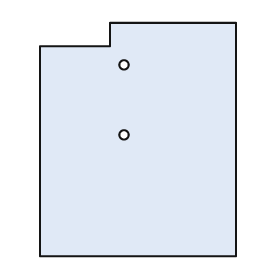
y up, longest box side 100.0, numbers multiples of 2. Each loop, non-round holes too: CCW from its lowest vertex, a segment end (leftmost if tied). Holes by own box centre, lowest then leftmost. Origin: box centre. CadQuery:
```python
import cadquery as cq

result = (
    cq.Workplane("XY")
    .moveTo(-42.0, -50.0)
    .lineTo(42.0, -50.0)
    .lineTo(42.0, 50.0)
    .lineTo(-12.0, 50.0)
    .lineTo(-12.0, 40.0)
    .lineTo(-42.0, 40.0)
    .close()
    .moveTo(-6.0, 2.0)
    .circle(2.0)
    .moveTo(-6.0, 32.0)
    .circle(2.0)
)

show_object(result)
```